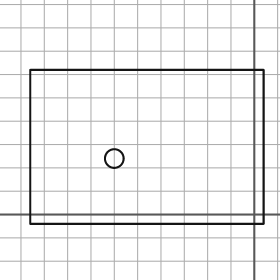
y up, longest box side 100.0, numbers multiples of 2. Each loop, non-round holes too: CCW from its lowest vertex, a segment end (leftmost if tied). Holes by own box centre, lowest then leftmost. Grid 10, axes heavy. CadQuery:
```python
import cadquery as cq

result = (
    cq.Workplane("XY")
    .moveTo(-96.0, -4.0)
    .lineTo(4.0, -4.0)
    .lineTo(4.0, 62.0)
    .lineTo(-96.0, 62.0)
    .close()
    .moveTo(-60.0, 24.0)
    .circle(4.0)
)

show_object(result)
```